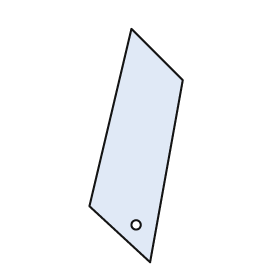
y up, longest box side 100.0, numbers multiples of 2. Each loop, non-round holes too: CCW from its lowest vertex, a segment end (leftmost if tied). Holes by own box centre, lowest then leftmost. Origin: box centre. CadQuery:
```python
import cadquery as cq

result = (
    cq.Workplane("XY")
    .moveTo(6.0, -50.0)
    .lineTo(20.0, 28.0)
    .lineTo(-2.0, 50.0)
    .lineTo(-20.0, -26.0)
    .close()
    .moveTo(0.0, -34.0)
    .circle(2.0)
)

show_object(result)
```